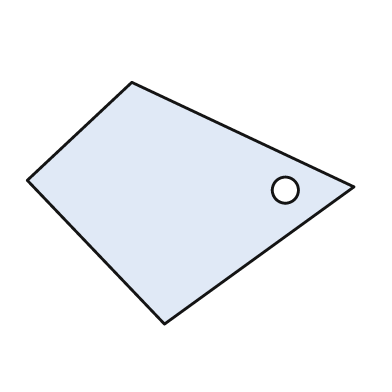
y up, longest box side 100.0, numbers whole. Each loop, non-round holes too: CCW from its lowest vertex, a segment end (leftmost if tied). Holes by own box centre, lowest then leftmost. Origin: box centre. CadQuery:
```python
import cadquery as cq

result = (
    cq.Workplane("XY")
    .moveTo(-8.0, -37.0)
    .lineTo(50.0, 5.0)
    .lineTo(-18.0, 37.0)
    .lineTo(-50.0, 7.0)
    .close()
    .moveTo(29.0, 4.0)
    .circle(4.0)
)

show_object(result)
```